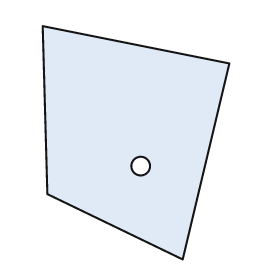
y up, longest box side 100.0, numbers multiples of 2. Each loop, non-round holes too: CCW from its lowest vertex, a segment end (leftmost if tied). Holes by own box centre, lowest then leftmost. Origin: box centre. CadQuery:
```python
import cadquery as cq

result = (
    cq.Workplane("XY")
    .moveTo(20.0, -50.0)
    .lineTo(40.0, 34.0)
    .lineTo(-40.0, 50.0)
    .lineTo(-38.0, -22.0)
    .close()
    .moveTo(2.0, -10.0)
    .circle(4.0)
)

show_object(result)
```